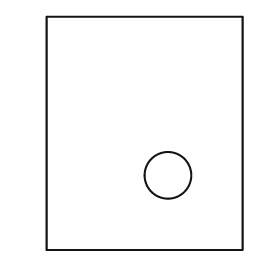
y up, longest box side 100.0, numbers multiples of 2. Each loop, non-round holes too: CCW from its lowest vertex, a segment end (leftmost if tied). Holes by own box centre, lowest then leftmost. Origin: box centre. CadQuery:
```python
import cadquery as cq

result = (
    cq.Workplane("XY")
    .moveTo(-42.0, -50.0)
    .lineTo(42.0, -50.0)
    .lineTo(42.0, 50.0)
    .lineTo(-42.0, 50.0)
    .close()
    .moveTo(10.0, -18.0)
    .circle(10.0)
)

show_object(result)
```